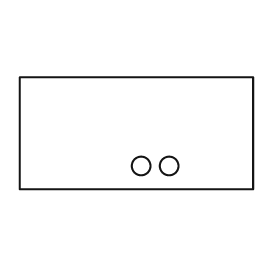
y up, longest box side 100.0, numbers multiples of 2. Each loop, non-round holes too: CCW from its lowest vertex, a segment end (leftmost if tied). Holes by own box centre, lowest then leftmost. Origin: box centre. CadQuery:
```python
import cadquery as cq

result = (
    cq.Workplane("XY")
    .moveTo(-50.0, -24.0)
    .lineTo(50.0, -24.0)
    .lineTo(50.0, 24.0)
    .lineTo(-50.0, 24.0)
    .close()
    .moveTo(2.0, -14.0)
    .circle(4.0)
    .moveTo(14.0, -14.0)
    .circle(4.0)
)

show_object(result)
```